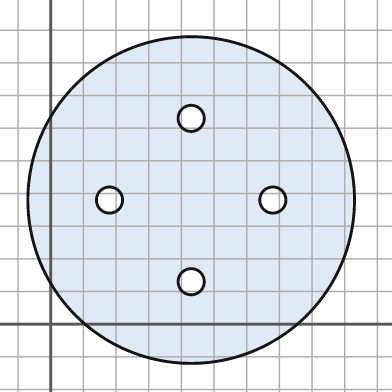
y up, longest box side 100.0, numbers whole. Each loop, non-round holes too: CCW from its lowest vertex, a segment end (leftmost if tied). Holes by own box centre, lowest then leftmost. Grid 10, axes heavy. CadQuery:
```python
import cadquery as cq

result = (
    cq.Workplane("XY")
    .moveTo(43.0, 38.0)
    .circle(50.0)
    .moveTo(43.0, 13.0)
    .circle(4.0)
    .moveTo(18.0, 38.0)
    .circle(4.0)
    .moveTo(68.0, 38.0)
    .circle(4.0)
    .moveTo(43.0, 63.0)
    .circle(4.0)
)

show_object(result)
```